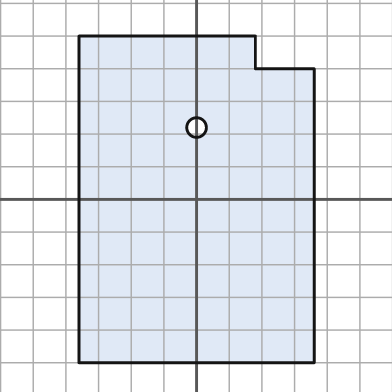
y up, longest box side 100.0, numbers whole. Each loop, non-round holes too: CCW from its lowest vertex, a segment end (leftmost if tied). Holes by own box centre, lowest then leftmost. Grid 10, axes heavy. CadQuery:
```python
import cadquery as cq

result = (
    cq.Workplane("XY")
    .moveTo(-36.0, -50.0)
    .lineTo(36.0, -50.0)
    .lineTo(36.0, 40.0)
    .lineTo(18.0, 40.0)
    .lineTo(18.0, 50.0)
    .lineTo(-36.0, 50.0)
    .close()
    .moveTo(0.0, 22.0)
    .circle(3.0)
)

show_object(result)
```